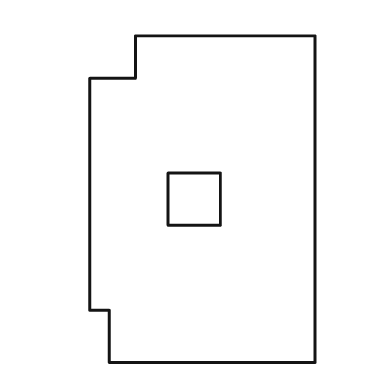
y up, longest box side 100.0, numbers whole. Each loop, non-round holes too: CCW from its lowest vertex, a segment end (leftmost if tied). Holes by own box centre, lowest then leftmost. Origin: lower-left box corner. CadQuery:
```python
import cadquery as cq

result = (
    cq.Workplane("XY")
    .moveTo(6.0, 0.0)
    .lineTo(69.0, 0.0)
    .lineTo(69.0, 100.0)
    .lineTo(14.0, 100.0)
    .lineTo(14.0, 87.0)
    .lineTo(0.0, 87.0)
    .lineTo(0.0, 16.0)
    .lineTo(6.0, 16.0)
    .close()
    .moveTo(24.0, 42.0)
    .lineTo(40.0, 42.0)
    .lineTo(40.0, 58.0)
    .lineTo(24.0, 58.0)
    .close()
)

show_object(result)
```